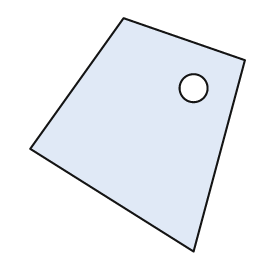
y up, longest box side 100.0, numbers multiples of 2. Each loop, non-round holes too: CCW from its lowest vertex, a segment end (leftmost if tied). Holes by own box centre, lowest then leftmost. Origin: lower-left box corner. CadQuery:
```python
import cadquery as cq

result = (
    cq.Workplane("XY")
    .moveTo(70.0, 0.0)
    .lineTo(92.0, 82.0)
    .lineTo(40.0, 100.0)
    .lineTo(0.0, 44.0)
    .close()
    .moveTo(70.0, 70.0)
    .circle(6.0)
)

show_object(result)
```